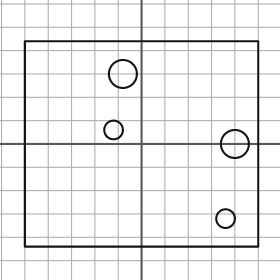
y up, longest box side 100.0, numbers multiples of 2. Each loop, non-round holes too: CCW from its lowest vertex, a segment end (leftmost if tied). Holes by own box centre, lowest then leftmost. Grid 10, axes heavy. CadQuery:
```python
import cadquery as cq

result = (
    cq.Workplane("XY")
    .moveTo(-50.0, -44.0)
    .lineTo(50.0, -44.0)
    .lineTo(50.0, 44.0)
    .lineTo(-50.0, 44.0)
    .close()
    .moveTo(36.0, -32.0)
    .circle(4.0)
    .moveTo(40.0, 0.0)
    .circle(6.0)
    .moveTo(-12.0, 6.0)
    .circle(4.0)
    .moveTo(-8.0, 30.0)
    .circle(6.0)
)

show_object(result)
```